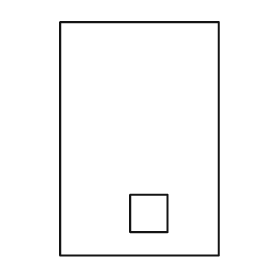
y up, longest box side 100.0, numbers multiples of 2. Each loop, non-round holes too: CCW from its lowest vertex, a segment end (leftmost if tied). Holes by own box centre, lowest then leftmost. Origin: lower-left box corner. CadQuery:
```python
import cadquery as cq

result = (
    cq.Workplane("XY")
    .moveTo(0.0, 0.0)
    .lineTo(68.0, 0.0)
    .lineTo(68.0, 100.0)
    .lineTo(0.0, 100.0)
    .close()
    .moveTo(30.0, 10.0)
    .lineTo(46.0, 10.0)
    .lineTo(46.0, 26.0)
    .lineTo(30.0, 26.0)
    .close()
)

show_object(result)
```